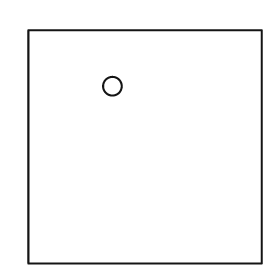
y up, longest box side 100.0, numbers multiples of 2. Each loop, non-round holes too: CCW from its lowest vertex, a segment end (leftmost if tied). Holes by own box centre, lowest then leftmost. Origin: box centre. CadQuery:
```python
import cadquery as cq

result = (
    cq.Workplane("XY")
    .moveTo(-50.0, -50.0)
    .lineTo(50.0, -50.0)
    .lineTo(50.0, 50.0)
    .lineTo(-50.0, 50.0)
    .close()
    .moveTo(-14.0, 26.0)
    .circle(4.0)
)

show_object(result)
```